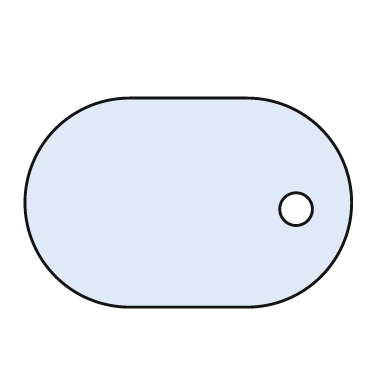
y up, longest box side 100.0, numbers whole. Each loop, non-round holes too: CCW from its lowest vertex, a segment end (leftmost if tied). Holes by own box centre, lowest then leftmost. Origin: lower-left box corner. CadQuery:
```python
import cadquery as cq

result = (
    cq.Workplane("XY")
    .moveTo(32.0, 0.0)
    .lineTo(68.0, 0.0)
    .threePointArc((100.0, 32.0), (68.0, 64.0))
    .lineTo(32.0, 64.0)
    .threePointArc((0.0, 32.0), (32.0, 0.0))
    .close()
    .moveTo(83.0, 30.0)
    .circle(5.0)
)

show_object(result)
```